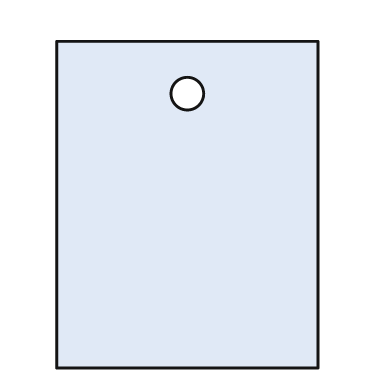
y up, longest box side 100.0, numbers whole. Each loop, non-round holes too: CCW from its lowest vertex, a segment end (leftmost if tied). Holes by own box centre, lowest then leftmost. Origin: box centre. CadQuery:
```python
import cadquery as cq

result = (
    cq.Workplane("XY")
    .moveTo(-40.0, -50.0)
    .lineTo(40.0, -50.0)
    .lineTo(40.0, 50.0)
    .lineTo(-40.0, 50.0)
    .close()
    .moveTo(0.0, 34.0)
    .circle(5.0)
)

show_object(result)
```